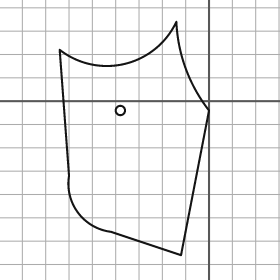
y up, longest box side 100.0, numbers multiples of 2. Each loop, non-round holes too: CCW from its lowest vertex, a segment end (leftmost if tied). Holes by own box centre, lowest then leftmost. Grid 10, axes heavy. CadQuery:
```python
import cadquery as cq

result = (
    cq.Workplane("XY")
    .moveTo(-12.0, -66.0)
    .lineTo(0.0, -4.0)
    .threePointArc((-10.0, 14.0), (-14.0, 34.0))
    .threePointArc((-36.0, 16.0), (-64.0, 22.0))
    .lineTo(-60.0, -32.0)
    .threePointArc((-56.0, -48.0), (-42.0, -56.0))
    .close()
    .moveTo(-38.0, -4.0)
    .circle(2.0)
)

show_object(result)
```